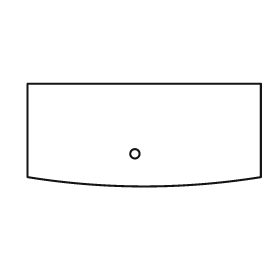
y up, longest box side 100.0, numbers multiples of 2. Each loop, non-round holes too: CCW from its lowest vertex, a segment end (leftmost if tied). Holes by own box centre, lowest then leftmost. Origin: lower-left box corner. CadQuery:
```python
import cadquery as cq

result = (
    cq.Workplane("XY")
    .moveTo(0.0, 4.0)
    .threePointArc((50.0, 0.0), (100.0, 4.0))
    .lineTo(100.0, 44.0)
    .lineTo(0.0, 44.0)
    .close()
    .moveTo(46.0, 14.0)
    .circle(2.0)
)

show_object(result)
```